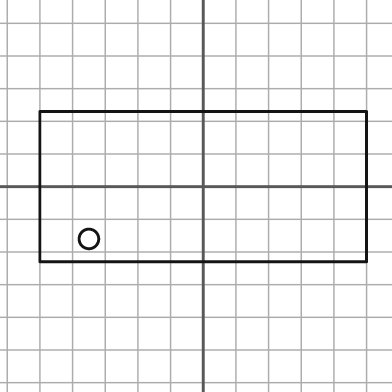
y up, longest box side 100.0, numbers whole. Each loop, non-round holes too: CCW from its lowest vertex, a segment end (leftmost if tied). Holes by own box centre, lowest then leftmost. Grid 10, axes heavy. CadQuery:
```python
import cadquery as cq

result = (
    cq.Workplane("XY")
    .moveTo(-50.0, -23.0)
    .lineTo(50.0, -23.0)
    .lineTo(50.0, 23.0)
    .lineTo(-50.0, 23.0)
    .close()
    .moveTo(-35.0, -16.0)
    .circle(3.0)
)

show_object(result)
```